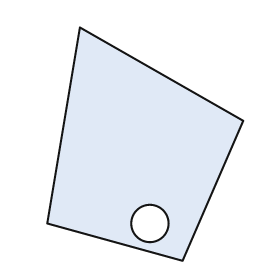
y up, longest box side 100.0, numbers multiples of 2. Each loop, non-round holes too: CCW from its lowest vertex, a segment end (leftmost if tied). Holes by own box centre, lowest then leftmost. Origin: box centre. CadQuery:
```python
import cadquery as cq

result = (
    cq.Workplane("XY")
    .moveTo(16.0, -50.0)
    .lineTo(42.0, 10.0)
    .lineTo(-28.0, 50.0)
    .lineTo(-42.0, -34.0)
    .close()
    .moveTo(2.0, -34.0)
    .circle(8.0)
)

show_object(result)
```